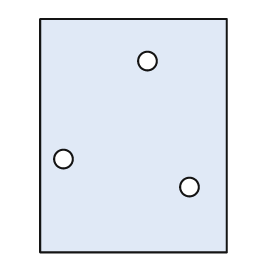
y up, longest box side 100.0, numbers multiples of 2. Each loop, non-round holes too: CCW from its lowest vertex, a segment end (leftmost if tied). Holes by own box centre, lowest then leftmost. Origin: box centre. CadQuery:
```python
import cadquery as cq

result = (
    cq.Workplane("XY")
    .moveTo(-40.0, -50.0)
    .lineTo(40.0, -50.0)
    .lineTo(40.0, 50.0)
    .lineTo(-40.0, 50.0)
    .close()
    .moveTo(24.0, -22.0)
    .circle(4.0)
    .moveTo(-30.0, -10.0)
    .circle(4.0)
    .moveTo(6.0, 32.0)
    .circle(4.0)
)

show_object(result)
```